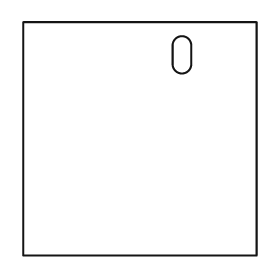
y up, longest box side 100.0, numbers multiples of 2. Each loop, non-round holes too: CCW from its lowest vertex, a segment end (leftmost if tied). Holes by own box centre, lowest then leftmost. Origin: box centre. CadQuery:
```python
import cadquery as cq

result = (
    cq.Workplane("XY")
    .moveTo(-50.0, -50.0)
    .lineTo(50.0, -50.0)
    .lineTo(50.0, 50.0)
    .lineTo(-50.0, 50.0)
    .close()
    .moveTo(14.0, 32.0)
    .threePointArc((18.0, 28.0), (22.0, 32.0))
    .lineTo(22.0, 40.0)
    .threePointArc((18.0, 44.0), (14.0, 40.0))
    .close()
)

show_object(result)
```